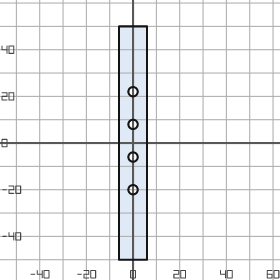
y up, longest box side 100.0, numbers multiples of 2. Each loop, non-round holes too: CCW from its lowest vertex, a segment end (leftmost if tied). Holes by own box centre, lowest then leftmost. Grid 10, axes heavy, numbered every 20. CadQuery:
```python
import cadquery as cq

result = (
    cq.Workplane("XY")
    .moveTo(-6.0, -50.0)
    .lineTo(6.0, -50.0)
    .lineTo(6.0, 50.0)
    .lineTo(-6.0, 50.0)
    .close()
    .moveTo(0.0, -20.0)
    .circle(2.0)
    .moveTo(0.0, -6.0)
    .circle(2.0)
    .moveTo(0.0, 8.0)
    .circle(2.0)
    .moveTo(0.0, 22.0)
    .circle(2.0)
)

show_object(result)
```